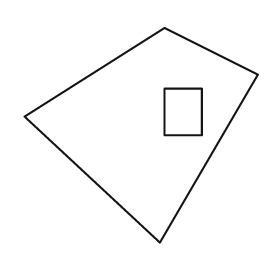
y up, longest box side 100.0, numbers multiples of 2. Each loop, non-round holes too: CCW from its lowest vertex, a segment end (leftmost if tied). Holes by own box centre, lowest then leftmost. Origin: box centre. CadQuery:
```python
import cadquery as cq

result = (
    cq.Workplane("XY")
    .moveTo(8.0, -46.0)
    .lineTo(50.0, 26.0)
    .lineTo(10.0, 46.0)
    .lineTo(-50.0, 8.0)
    .close()
    .moveTo(10.0, 0.0)
    .lineTo(26.0, 0.0)
    .lineTo(26.0, 20.0)
    .lineTo(10.0, 20.0)
    .close()
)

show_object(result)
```